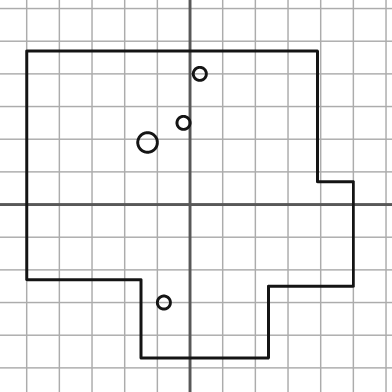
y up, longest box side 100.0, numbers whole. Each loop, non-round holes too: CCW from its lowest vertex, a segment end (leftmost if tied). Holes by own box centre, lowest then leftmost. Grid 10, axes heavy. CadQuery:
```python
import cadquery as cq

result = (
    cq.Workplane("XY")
    .moveTo(-15.0, -47.0)
    .lineTo(24.0, -47.0)
    .lineTo(24.0, -25.0)
    .lineTo(50.0, -25.0)
    .lineTo(50.0, 7.0)
    .lineTo(39.0, 7.0)
    .lineTo(39.0, 47.0)
    .lineTo(-50.0, 47.0)
    .lineTo(-50.0, -23.0)
    .lineTo(-15.0, -23.0)
    .close()
    .moveTo(-8.0, -30.0)
    .circle(2.0)
    .moveTo(-13.0, 19.0)
    .circle(3.0)
    .moveTo(-2.0, 25.0)
    .circle(2.0)
    .moveTo(3.0, 40.0)
    .circle(2.0)
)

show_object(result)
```